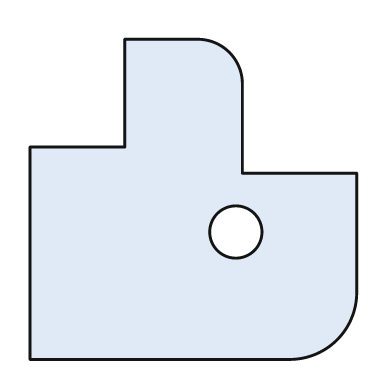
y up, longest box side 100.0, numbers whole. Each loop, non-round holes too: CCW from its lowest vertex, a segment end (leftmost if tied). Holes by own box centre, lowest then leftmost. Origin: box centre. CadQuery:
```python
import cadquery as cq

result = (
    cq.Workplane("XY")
    .moveTo(-50.0, -49.0)
    .lineTo(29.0, -49.0)
    .threePointArc((44.0, -43.0), (50.0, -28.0))
    .lineTo(50.0, 8.0)
    .lineTo(15.0, 8.0)
    .lineTo(15.0, 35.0)
    .threePointArc((11.0, 45.0), (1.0, 49.0))
    .lineTo(-21.0, 49.0)
    .lineTo(-21.0, 16.0)
    .lineTo(-50.0, 16.0)
    .close()
    .moveTo(13.0, -10.0)
    .circle(8.0)
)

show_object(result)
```